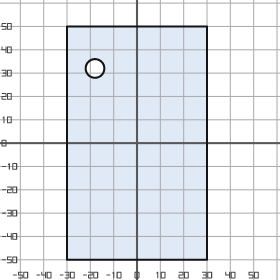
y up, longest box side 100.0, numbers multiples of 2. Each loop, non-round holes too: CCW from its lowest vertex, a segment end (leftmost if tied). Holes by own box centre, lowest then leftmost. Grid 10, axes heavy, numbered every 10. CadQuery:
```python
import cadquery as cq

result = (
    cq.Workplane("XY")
    .moveTo(-30.0, -50.0)
    .lineTo(30.0, -50.0)
    .lineTo(30.0, 50.0)
    .lineTo(-30.0, 50.0)
    .close()
    .moveTo(-18.0, 32.0)
    .circle(4.0)
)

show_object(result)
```